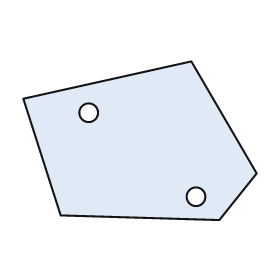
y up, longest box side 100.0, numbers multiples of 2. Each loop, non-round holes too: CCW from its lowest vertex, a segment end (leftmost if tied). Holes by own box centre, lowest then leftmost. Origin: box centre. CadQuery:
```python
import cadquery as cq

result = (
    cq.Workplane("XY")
    .moveTo(34.0, -34.0)
    .lineTo(50.0, -14.0)
    .lineTo(22.0, 34.0)
    .lineTo(-50.0, 18.0)
    .lineTo(-34.0, -32.0)
    .close()
    .moveTo(24.0, -24.0)
    .circle(4.0)
    .moveTo(-22.0, 12.0)
    .circle(4.0)
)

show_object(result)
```